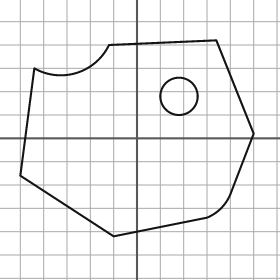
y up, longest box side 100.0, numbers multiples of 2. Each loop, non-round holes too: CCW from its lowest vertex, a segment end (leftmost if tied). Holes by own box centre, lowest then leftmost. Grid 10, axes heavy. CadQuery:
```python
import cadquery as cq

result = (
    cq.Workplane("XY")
    .moveTo(-10.0, -42.0)
    .lineTo(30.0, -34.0)
    .threePointArc((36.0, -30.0), (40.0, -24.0))
    .lineTo(50.0, 2.0)
    .lineTo(34.0, 42.0)
    .lineTo(-12.0, 40.0)
    .threePointArc((-26.0, 28.0), (-44.0, 30.0))
    .lineTo(-50.0, -16.0)
    .close()
    .moveTo(18.0, 18.0)
    .circle(8.0)
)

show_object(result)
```